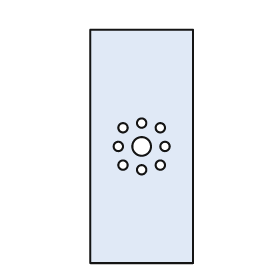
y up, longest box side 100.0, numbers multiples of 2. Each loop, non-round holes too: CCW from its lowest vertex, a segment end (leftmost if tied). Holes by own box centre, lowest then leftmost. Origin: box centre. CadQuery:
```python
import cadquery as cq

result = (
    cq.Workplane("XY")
    .moveTo(-22.0, -50.0)
    .lineTo(22.0, -50.0)
    .lineTo(22.0, 50.0)
    .lineTo(-22.0, 50.0)
    .close()
    .moveTo(0.0, -10.0)
    .circle(2.0)
    .moveTo(-8.0, -8.0)
    .circle(2.0)
    .moveTo(8.0, -8.0)
    .circle(2.0)
    .moveTo(-10.0, 0.0)
    .circle(2.0)
    .moveTo(0.0, 0.0)
    .circle(4.0)
    .moveTo(10.0, 0.0)
    .circle(2.0)
    .moveTo(-8.0, 8.0)
    .circle(2.0)
    .moveTo(8.0, 8.0)
    .circle(2.0)
    .moveTo(0.0, 10.0)
    .circle(2.0)
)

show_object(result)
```